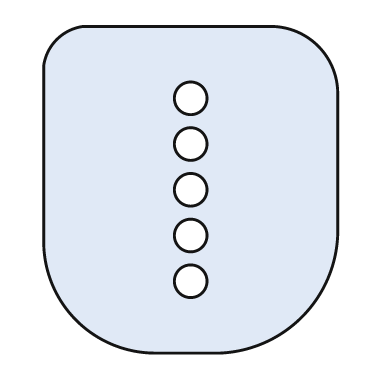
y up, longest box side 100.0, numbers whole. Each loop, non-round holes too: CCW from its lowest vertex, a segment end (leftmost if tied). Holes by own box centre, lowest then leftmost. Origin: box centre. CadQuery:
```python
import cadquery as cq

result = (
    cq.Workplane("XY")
    .moveTo(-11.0, -50.0)
    .lineTo(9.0, -50.0)
    .threePointArc((34.0, -39.0), (45.0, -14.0))
    .lineTo(45.0, 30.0)
    .threePointArc((39.0, 44.0), (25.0, 50.0))
    .lineTo(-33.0, 50.0)
    .threePointArc((-41.0, 46.0), (-45.0, 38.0))
    .lineTo(-45.0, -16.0)
    .threePointArc((-35.0, -40.0), (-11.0, -50.0))
    .close()
    .moveTo(0.0, -28.0)
    .circle(5.0)
    .moveTo(0.0, -14.0)
    .circle(5.0)
    .moveTo(0.0, 0.0)
    .circle(5.0)
    .moveTo(0.0, 14.0)
    .circle(5.0)
    .moveTo(0.0, 28.0)
    .circle(5.0)
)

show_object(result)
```